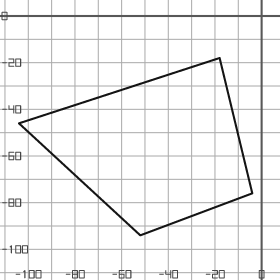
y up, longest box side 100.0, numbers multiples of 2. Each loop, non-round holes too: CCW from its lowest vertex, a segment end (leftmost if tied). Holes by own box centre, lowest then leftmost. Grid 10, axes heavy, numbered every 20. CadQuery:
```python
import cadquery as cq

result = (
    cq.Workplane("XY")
    .moveTo(-52.0, -94.0)
    .lineTo(-4.0, -76.0)
    .lineTo(-18.0, -18.0)
    .lineTo(-104.0, -46.0)
    .close()
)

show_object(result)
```